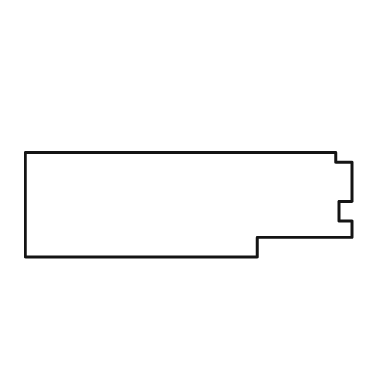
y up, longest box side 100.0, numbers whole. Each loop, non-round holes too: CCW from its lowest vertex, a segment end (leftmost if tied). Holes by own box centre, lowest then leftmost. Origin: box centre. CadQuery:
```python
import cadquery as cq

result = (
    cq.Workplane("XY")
    .moveTo(-50.0, -16.0)
    .lineTo(21.0, -16.0)
    .lineTo(21.0, -10.0)
    .lineTo(50.0, -10.0)
    .lineTo(50.0, -5.0)
    .lineTo(46.0, -5.0)
    .lineTo(46.0, 1.0)
    .lineTo(50.0, 1.0)
    .lineTo(50.0, 13.0)
    .lineTo(45.0, 13.0)
    .lineTo(45.0, 16.0)
    .lineTo(-50.0, 16.0)
    .close()
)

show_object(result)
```